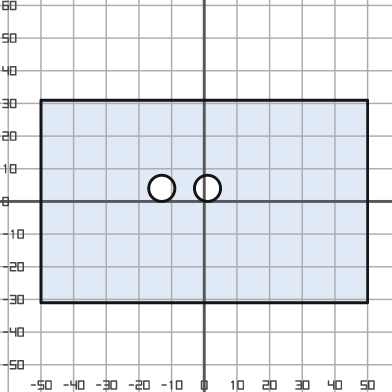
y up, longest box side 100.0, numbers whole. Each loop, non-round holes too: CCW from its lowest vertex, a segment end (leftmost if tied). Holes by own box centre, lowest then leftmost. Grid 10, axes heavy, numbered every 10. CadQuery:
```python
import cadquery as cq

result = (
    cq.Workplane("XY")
    .moveTo(-50.0, -31.0)
    .lineTo(50.0, -31.0)
    .lineTo(50.0, 31.0)
    .lineTo(-50.0, 31.0)
    .close()
    .moveTo(-13.0, 4.0)
    .circle(4.0)
    .moveTo(1.0, 4.0)
    .circle(4.0)
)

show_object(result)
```